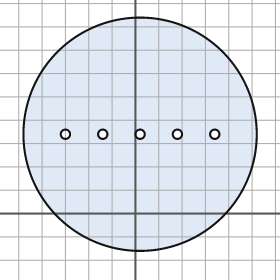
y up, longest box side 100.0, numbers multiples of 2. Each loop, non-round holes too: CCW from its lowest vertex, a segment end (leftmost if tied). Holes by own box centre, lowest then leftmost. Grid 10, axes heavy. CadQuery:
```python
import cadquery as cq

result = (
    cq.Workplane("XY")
    .moveTo(2.0, 34.0)
    .circle(50.0)
    .moveTo(-30.0, 34.0)
    .circle(2.0)
    .moveTo(-14.0, 34.0)
    .circle(2.0)
    .moveTo(2.0, 34.0)
    .circle(2.0)
    .moveTo(18.0, 34.0)
    .circle(2.0)
    .moveTo(34.0, 34.0)
    .circle(2.0)
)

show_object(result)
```